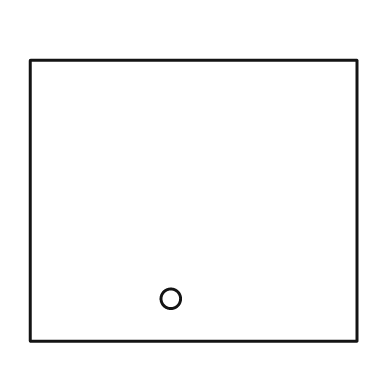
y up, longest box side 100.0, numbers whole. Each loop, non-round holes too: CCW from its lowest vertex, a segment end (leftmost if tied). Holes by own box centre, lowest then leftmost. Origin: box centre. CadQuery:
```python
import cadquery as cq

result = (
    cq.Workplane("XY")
    .moveTo(-50.0, -43.0)
    .lineTo(50.0, -43.0)
    .lineTo(50.0, 43.0)
    .lineTo(-50.0, 43.0)
    .close()
    .moveTo(-7.0, -30.0)
    .circle(3.0)
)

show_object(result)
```